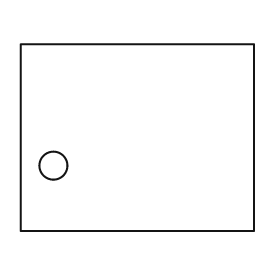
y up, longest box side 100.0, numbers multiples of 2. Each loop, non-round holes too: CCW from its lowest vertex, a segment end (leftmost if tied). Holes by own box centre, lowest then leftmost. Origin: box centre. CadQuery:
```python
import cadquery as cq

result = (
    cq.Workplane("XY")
    .moveTo(-50.0, -40.0)
    .lineTo(50.0, -40.0)
    .lineTo(50.0, 40.0)
    .lineTo(-50.0, 40.0)
    .close()
    .moveTo(-36.0, -12.0)
    .circle(6.0)
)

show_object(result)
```